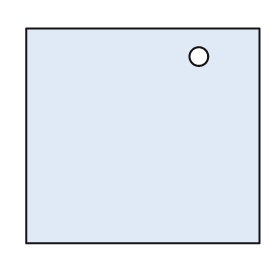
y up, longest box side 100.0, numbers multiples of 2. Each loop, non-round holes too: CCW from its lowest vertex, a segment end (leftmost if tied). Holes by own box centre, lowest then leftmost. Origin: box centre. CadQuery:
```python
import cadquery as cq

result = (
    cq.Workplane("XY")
    .moveTo(-50.0, -46.0)
    .lineTo(50.0, -46.0)
    .lineTo(50.0, 46.0)
    .lineTo(-50.0, 46.0)
    .close()
    .moveTo(24.0, 34.0)
    .circle(4.0)
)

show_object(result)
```